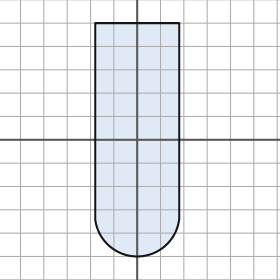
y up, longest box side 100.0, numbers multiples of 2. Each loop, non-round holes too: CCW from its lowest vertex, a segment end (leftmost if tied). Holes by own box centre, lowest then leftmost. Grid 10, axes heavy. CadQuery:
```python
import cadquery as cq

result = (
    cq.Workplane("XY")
    .moveTo(-18.0, -34.0)
    .threePointArc((0.0, -50.0), (18.0, -34.0))
    .lineTo(18.0, 50.0)
    .lineTo(-18.0, 50.0)
    .close()
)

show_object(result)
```